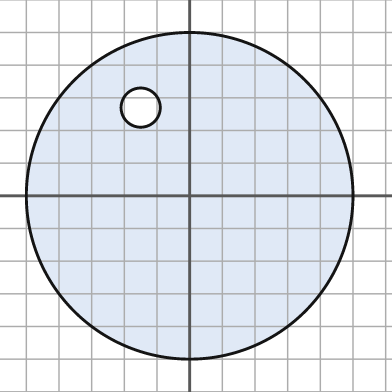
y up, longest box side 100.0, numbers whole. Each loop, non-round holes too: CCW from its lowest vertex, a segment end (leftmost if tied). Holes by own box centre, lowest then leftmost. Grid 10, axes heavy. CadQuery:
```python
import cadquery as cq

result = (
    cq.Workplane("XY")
    .moveTo(0.0, 0.0)
    .circle(50.0)
    .moveTo(-15.0, 27.0)
    .circle(6.0)
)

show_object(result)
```